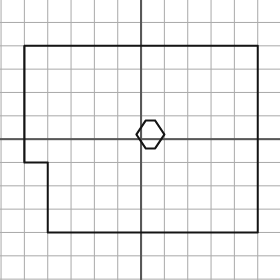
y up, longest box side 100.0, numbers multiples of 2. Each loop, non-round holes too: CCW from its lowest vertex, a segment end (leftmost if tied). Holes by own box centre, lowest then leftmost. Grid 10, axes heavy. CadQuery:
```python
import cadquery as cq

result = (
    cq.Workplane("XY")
    .moveTo(-40.0, -40.0)
    .lineTo(50.0, -40.0)
    .lineTo(50.0, 40.0)
    .lineTo(-50.0, 40.0)
    .lineTo(-50.0, -10.0)
    .lineTo(-40.0, -10.0)
    .close()
    .moveTo(2.0, -4.0)
    .lineTo(6.0, -4.0)
    .lineTo(10.0, 2.0)
    .lineTo(6.0, 8.0)
    .lineTo(2.0, 8.0)
    .lineTo(-2.0, 2.0)
    .close()
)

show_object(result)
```